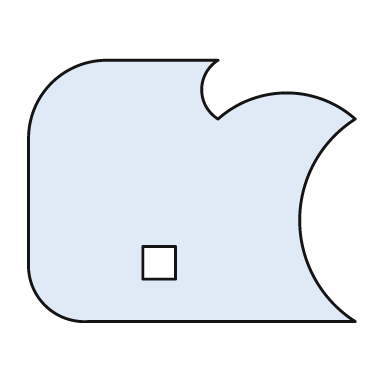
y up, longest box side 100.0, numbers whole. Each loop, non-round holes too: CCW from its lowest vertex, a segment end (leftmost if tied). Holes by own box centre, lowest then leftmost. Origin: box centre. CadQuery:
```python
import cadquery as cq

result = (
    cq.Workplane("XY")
    .moveTo(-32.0, -40.0)
    .lineTo(50.0, -40.0)
    .threePointArc((33.0, -9.0), (50.0, 22.0))
    .threePointArc((29.0, 30.0), (8.0, 22.0))
    .threePointArc((3.0, 31.0), (8.0, 40.0))
    .lineTo(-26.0, 40.0)
    .threePointArc((-43.0, 33.0), (-50.0, 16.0))
    .lineTo(-50.0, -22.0)
    .threePointArc((-45.0, -35.0), (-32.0, -40.0))
    .close()
    .moveTo(-15.0, -27.0)
    .lineTo(-5.0, -27.0)
    .lineTo(-5.0, -17.0)
    .lineTo(-15.0, -17.0)
    .close()
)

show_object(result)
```